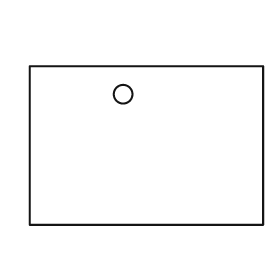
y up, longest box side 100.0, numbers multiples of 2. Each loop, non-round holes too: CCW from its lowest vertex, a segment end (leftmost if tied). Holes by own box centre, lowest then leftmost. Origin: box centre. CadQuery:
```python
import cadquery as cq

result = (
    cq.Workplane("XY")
    .moveTo(-50.0, -34.0)
    .lineTo(50.0, -34.0)
    .lineTo(50.0, 34.0)
    .lineTo(-50.0, 34.0)
    .close()
    .moveTo(-10.0, 22.0)
    .circle(4.0)
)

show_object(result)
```